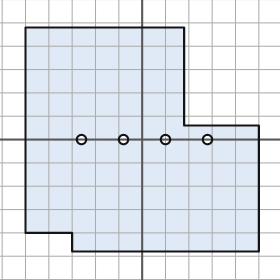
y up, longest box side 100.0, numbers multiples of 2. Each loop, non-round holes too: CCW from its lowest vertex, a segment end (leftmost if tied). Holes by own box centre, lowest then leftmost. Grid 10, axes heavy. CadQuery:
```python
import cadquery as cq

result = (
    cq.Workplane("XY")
    .moveTo(-30.0, -48.0)
    .lineTo(50.0, -48.0)
    .lineTo(50.0, 6.0)
    .lineTo(18.0, 6.0)
    .lineTo(18.0, 48.0)
    .lineTo(-50.0, 48.0)
    .lineTo(-50.0, -40.0)
    .lineTo(-30.0, -40.0)
    .close()
    .moveTo(-26.0, 0.0)
    .circle(2.0)
    .moveTo(-8.0, 0.0)
    .circle(2.0)
    .moveTo(10.0, 0.0)
    .circle(2.0)
    .moveTo(28.0, 0.0)
    .circle(2.0)
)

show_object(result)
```